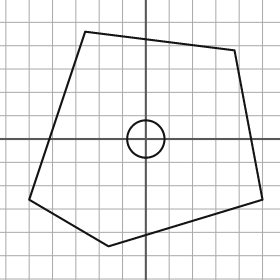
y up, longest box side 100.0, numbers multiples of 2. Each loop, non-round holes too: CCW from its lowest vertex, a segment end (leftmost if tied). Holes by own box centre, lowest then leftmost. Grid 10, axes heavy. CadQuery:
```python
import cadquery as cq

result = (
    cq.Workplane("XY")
    .moveTo(-16.0, -46.0)
    .lineTo(50.0, -26.0)
    .lineTo(38.0, 38.0)
    .lineTo(-26.0, 46.0)
    .lineTo(-50.0, -26.0)
    .close()
    .moveTo(0.0, 0.0)
    .circle(8.0)
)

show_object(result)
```